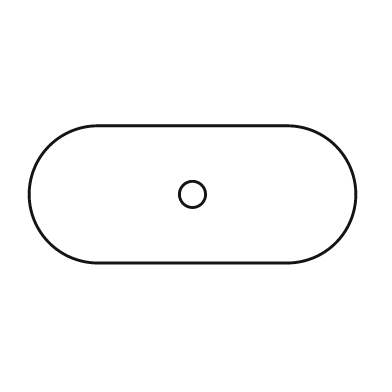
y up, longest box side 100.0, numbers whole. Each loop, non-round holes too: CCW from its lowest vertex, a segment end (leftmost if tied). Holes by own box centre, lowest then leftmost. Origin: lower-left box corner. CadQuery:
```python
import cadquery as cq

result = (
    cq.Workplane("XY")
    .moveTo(21.0, 0.0)
    .lineTo(79.0, 0.0)
    .threePointArc((100.0, 21.0), (79.0, 42.0))
    .lineTo(21.0, 42.0)
    .threePointArc((0.0, 21.0), (21.0, 0.0))
    .close()
    .moveTo(50.0, 21.0)
    .circle(4.0)
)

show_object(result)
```